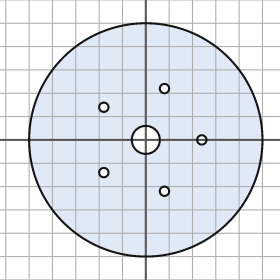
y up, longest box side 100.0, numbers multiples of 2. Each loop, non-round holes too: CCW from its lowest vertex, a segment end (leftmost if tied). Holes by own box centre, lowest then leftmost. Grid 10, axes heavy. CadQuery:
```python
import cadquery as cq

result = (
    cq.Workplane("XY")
    .moveTo(0.0, 0.0)
    .circle(50.0)
    .moveTo(8.0, -22.0)
    .circle(2.0)
    .moveTo(-18.0, -14.0)
    .circle(2.0)
    .moveTo(0.0, 0.0)
    .circle(6.0)
    .moveTo(24.0, 0.0)
    .circle(2.0)
    .moveTo(-18.0, 14.0)
    .circle(2.0)
    .moveTo(8.0, 22.0)
    .circle(2.0)
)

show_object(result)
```